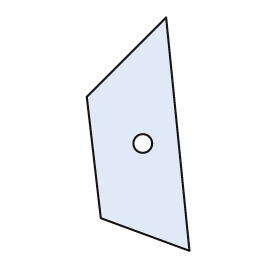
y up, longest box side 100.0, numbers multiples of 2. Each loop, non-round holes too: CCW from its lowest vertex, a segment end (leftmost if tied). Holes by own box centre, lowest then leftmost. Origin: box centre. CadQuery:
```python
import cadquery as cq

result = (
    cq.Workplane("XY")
    .moveTo(22.0, -50.0)
    .lineTo(12.0, 50.0)
    .lineTo(-22.0, 16.0)
    .lineTo(-16.0, -36.0)
    .close()
    .moveTo(2.0, -4.0)
    .circle(4.0)
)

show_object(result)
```